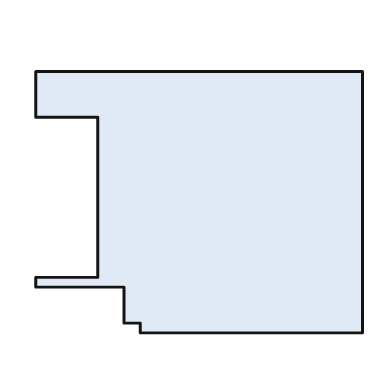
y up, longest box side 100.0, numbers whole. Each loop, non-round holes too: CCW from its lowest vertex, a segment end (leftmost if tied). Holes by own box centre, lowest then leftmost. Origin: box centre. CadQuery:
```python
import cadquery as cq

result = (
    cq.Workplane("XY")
    .moveTo(-18.0, -40.0)
    .lineTo(50.0, -40.0)
    .lineTo(50.0, 40.0)
    .lineTo(-50.0, 40.0)
    .lineTo(-50.0, 26.0)
    .lineTo(-31.0, 26.0)
    .lineTo(-31.0, -23.0)
    .lineTo(-50.0, -23.0)
    .lineTo(-50.0, -26.0)
    .lineTo(-23.0, -26.0)
    .lineTo(-23.0, -37.0)
    .lineTo(-18.0, -37.0)
    .close()
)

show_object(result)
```